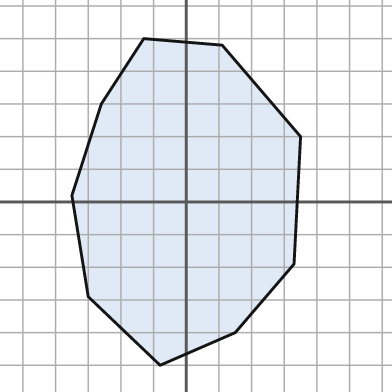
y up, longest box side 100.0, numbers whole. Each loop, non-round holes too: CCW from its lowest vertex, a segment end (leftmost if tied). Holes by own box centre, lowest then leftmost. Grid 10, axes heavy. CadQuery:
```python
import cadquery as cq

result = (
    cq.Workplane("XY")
    .moveTo(-8.0, -50.0)
    .lineTo(15.0, -40.0)
    .lineTo(33.0, -19.0)
    .lineTo(35.0, 20.0)
    .lineTo(11.0, 48.0)
    .lineTo(-13.0, 50.0)
    .lineTo(-26.0, 30.0)
    .lineTo(-35.0, 2.0)
    .lineTo(-30.0, -29.0)
    .close()
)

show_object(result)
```